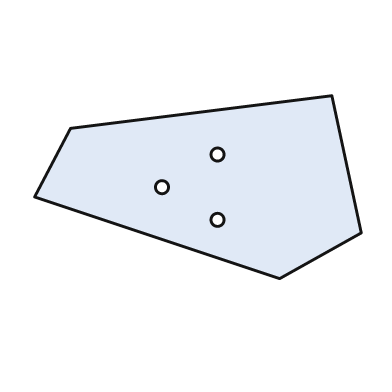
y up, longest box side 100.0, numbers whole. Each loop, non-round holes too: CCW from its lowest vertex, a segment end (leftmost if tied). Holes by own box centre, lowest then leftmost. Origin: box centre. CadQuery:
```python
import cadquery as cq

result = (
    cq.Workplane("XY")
    .moveTo(25.0, -28.0)
    .lineTo(50.0, -14.0)
    .lineTo(41.0, 28.0)
    .lineTo(-39.0, 18.0)
    .lineTo(-50.0, -3.0)
    .close()
    .moveTo(6.0, -10.0)
    .circle(2.0)
    .moveTo(-11.0, 0.0)
    .circle(2.0)
    .moveTo(6.0, 10.0)
    .circle(2.0)
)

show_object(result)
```